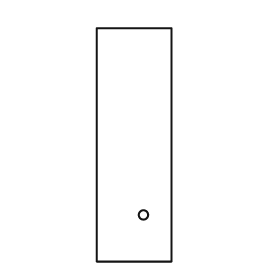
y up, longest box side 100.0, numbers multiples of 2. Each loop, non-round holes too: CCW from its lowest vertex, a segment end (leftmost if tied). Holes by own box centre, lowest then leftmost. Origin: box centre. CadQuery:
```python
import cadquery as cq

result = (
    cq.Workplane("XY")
    .moveTo(-16.0, -50.0)
    .lineTo(16.0, -50.0)
    .lineTo(16.0, 50.0)
    .lineTo(-16.0, 50.0)
    .close()
    .moveTo(4.0, -30.0)
    .circle(2.0)
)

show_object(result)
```